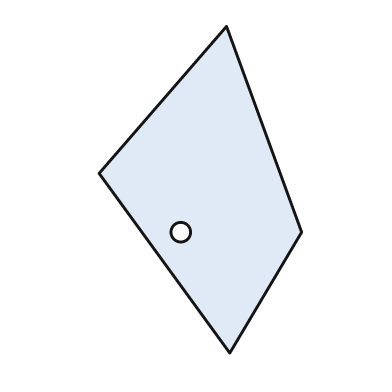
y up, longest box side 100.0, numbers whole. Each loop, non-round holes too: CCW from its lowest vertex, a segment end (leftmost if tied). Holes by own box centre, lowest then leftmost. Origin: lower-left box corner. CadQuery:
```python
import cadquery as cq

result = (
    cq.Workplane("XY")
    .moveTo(40.0, 0.0)
    .lineTo(62.0, 37.0)
    .lineTo(39.0, 100.0)
    .lineTo(0.0, 55.0)
    .close()
    .moveTo(25.0, 37.0)
    .circle(3.0)
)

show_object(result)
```